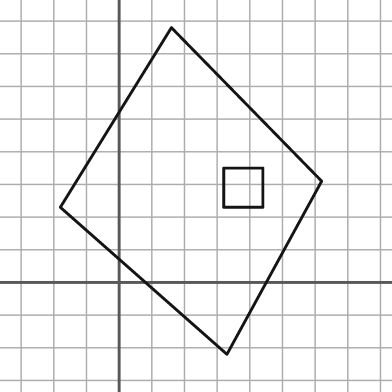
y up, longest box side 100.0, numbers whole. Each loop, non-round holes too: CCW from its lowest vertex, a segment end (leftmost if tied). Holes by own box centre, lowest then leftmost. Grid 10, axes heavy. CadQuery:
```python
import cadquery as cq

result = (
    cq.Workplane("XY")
    .moveTo(33.0, -22.0)
    .lineTo(62.0, 31.0)
    .lineTo(16.0, 78.0)
    .lineTo(-18.0, 23.0)
    .close()
    .moveTo(32.0, 23.0)
    .lineTo(44.0, 23.0)
    .lineTo(44.0, 35.0)
    .lineTo(32.0, 35.0)
    .close()
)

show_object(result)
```